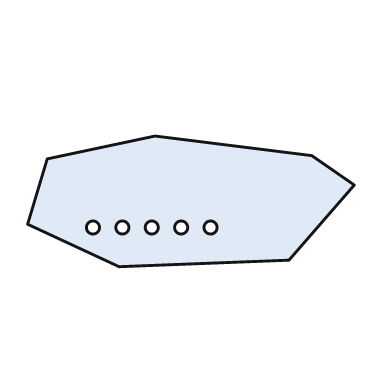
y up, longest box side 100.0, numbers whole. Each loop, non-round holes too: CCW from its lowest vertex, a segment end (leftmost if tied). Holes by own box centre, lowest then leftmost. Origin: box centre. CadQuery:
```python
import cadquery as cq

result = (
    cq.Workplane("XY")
    .moveTo(-22.0, -20.0)
    .lineTo(30.0, -18.0)
    .lineTo(50.0, 5.0)
    .lineTo(37.0, 14.0)
    .lineTo(-11.0, 20.0)
    .lineTo(-44.0, 13.0)
    .lineTo(-50.0, -7.0)
    .close()
    .moveTo(-30.0, -8.0)
    .circle(2.0)
    .moveTo(-21.0, -8.0)
    .circle(2.0)
    .moveTo(-12.0, -8.0)
    .circle(2.0)
    .moveTo(-3.0, -8.0)
    .circle(2.0)
    .moveTo(6.0, -8.0)
    .circle(2.0)
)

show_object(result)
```